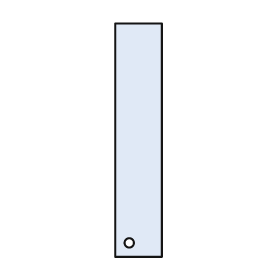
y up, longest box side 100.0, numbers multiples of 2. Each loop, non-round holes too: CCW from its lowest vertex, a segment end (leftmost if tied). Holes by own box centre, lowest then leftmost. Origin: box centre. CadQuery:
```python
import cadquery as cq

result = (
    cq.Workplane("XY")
    .moveTo(-10.0, -50.0)
    .lineTo(10.0, -50.0)
    .lineTo(10.0, 50.0)
    .lineTo(-10.0, 50.0)
    .close()
    .moveTo(-4.0, -44.0)
    .circle(2.0)
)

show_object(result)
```